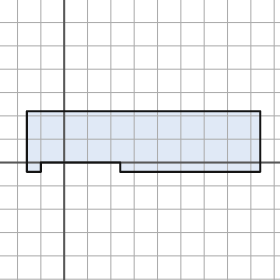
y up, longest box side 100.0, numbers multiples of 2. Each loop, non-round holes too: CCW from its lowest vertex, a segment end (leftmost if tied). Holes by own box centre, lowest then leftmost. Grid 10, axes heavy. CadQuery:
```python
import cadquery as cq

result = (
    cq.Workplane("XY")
    .moveTo(-16.0, -4.0)
    .lineTo(-10.0, -4.0)
    .lineTo(-10.0, 0.0)
    .lineTo(24.0, 0.0)
    .lineTo(24.0, -4.0)
    .lineTo(84.0, -4.0)
    .lineTo(84.0, 22.0)
    .lineTo(-16.0, 22.0)
    .close()
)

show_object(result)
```